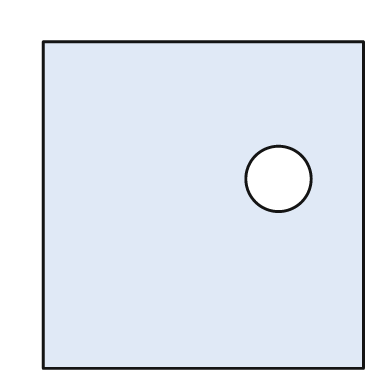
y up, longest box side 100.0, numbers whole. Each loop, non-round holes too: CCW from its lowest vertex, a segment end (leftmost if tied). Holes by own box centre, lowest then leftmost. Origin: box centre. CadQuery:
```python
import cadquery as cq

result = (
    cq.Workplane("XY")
    .moveTo(-49.0, -50.0)
    .lineTo(49.0, -50.0)
    .lineTo(49.0, 50.0)
    .lineTo(-49.0, 50.0)
    .close()
    .moveTo(23.0, 8.0)
    .circle(10.0)
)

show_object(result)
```